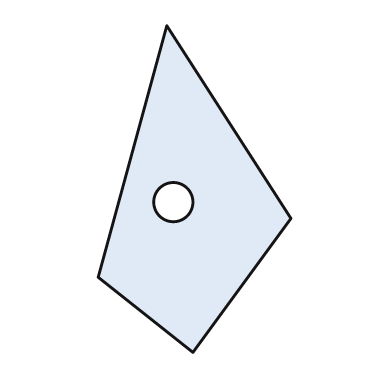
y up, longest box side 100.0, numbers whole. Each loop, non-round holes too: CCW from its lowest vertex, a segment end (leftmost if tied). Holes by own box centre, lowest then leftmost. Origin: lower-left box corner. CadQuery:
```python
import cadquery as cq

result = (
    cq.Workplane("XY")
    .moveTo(29.0, 0.0)
    .lineTo(59.0, 41.0)
    .lineTo(21.0, 100.0)
    .lineTo(0.0, 23.0)
    .close()
    .moveTo(23.0, 46.0)
    .circle(6.0)
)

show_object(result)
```